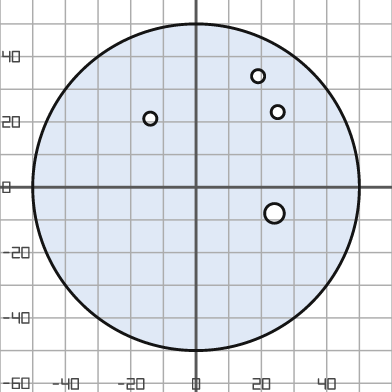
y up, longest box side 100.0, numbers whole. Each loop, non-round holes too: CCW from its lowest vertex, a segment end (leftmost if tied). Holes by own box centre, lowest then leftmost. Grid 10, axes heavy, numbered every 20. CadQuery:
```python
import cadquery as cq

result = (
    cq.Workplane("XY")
    .moveTo(0.0, 0.0)
    .circle(50.0)
    .moveTo(24.0, -8.0)
    .circle(3.0)
    .moveTo(-14.0, 21.0)
    .circle(2.0)
    .moveTo(25.0, 23.0)
    .circle(2.0)
    .moveTo(19.0, 34.0)
    .circle(2.0)
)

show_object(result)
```